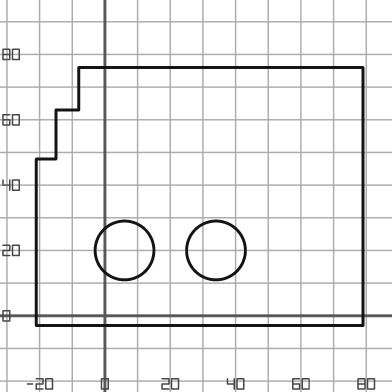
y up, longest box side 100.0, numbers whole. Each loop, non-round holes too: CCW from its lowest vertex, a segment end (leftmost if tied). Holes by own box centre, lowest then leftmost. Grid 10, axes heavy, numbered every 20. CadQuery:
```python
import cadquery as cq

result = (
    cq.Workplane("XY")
    .moveTo(-21.0, -3.0)
    .lineTo(79.0, -3.0)
    .lineTo(79.0, 76.0)
    .lineTo(-8.0, 76.0)
    .lineTo(-8.0, 63.0)
    .lineTo(-15.0, 63.0)
    .lineTo(-15.0, 48.0)
    .lineTo(-21.0, 48.0)
    .close()
    .moveTo(6.0, 20.0)
    .circle(9.0)
    .moveTo(34.0, 20.0)
    .circle(9.0)
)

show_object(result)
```